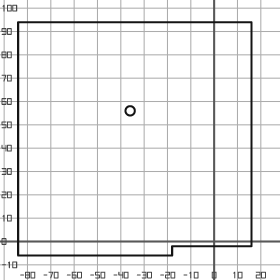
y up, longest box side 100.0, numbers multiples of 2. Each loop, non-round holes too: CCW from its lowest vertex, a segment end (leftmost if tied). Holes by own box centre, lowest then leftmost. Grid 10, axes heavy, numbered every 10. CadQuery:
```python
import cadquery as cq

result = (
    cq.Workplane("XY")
    .moveTo(-84.0, -6.0)
    .lineTo(-18.0, -6.0)
    .lineTo(-18.0, -2.0)
    .lineTo(16.0, -2.0)
    .lineTo(16.0, 94.0)
    .lineTo(-84.0, 94.0)
    .close()
    .moveTo(-36.0, 56.0)
    .circle(2.0)
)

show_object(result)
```